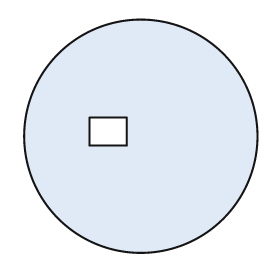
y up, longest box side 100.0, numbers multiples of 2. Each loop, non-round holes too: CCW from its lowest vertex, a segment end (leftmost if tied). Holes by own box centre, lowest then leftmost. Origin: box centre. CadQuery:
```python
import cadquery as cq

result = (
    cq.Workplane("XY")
    .moveTo(0.0, 0.0)
    .circle(50.0)
    .moveTo(-22.0, -4.0)
    .lineTo(-6.0, -4.0)
    .lineTo(-6.0, 8.0)
    .lineTo(-22.0, 8.0)
    .close()
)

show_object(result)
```